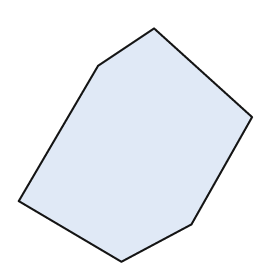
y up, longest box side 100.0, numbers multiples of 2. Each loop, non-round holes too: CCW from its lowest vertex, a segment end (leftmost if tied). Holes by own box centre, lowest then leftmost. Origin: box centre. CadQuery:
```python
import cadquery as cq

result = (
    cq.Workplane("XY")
    .moveTo(-6.0, -50.0)
    .lineTo(24.0, -34.0)
    .lineTo(50.0, 12.0)
    .lineTo(8.0, 50.0)
    .lineTo(-16.0, 34.0)
    .lineTo(-50.0, -24.0)
    .close()
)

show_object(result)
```